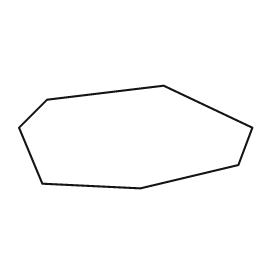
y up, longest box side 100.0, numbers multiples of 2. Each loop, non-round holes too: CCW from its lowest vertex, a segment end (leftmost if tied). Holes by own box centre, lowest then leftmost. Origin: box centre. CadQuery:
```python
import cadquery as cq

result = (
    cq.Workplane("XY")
    .moveTo(2.0, -22.0)
    .lineTo(44.0, -12.0)
    .lineTo(50.0, 4.0)
    .lineTo(12.0, 22.0)
    .lineTo(-38.0, 16.0)
    .lineTo(-50.0, 4.0)
    .lineTo(-40.0, -20.0)
    .close()
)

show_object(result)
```